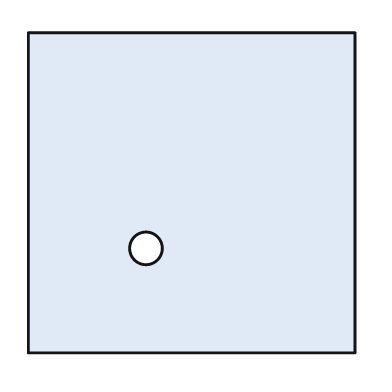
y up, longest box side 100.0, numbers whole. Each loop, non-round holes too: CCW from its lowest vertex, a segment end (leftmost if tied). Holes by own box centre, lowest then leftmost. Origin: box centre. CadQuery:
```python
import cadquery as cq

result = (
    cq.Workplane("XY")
    .moveTo(-50.0, -49.0)
    .lineTo(50.0, -49.0)
    .lineTo(50.0, 49.0)
    .lineTo(-50.0, 49.0)
    .close()
    .moveTo(-14.0, -17.0)
    .circle(5.0)
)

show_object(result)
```